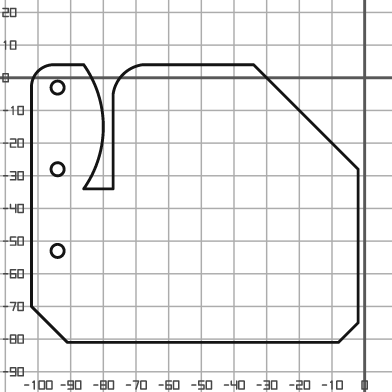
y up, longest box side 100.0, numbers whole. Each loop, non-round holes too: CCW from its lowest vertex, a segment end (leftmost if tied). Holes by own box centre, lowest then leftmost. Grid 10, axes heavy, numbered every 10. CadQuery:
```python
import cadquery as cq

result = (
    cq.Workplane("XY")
    .moveTo(-91.0, -81.0)
    .lineTo(-8.0, -81.0)
    .lineTo(-2.0, -75.0)
    .lineTo(-2.0, -28.0)
    .lineTo(-34.0, 4.0)
    .lineTo(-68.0, 4.0)
    .threePointArc((-74.0, 1.0), (-77.0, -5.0))
    .lineTo(-77.0, -34.0)
    .lineTo(-86.0, -34.0)
    .threePointArc((-80.0, -15.0), (-86.0, 4.0))
    .lineTo(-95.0, 4.0)
    .threePointArc((-100.0, 2.0), (-102.0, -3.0))
    .lineTo(-102.0, -70.0)
    .close()
    .moveTo(-94.0, -53.0)
    .circle(2.0)
    .moveTo(-94.0, -28.0)
    .circle(2.0)
    .moveTo(-94.0, -3.0)
    .circle(2.0)
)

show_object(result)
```